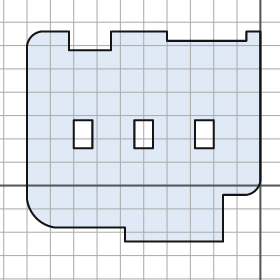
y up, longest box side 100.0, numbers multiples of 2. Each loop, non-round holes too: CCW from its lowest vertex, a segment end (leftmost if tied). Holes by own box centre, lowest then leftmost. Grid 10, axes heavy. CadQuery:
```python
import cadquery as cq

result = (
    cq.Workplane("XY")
    .moveTo(-58.0, -24.0)
    .lineTo(-16.0, -24.0)
    .lineTo(-16.0, -4.0)
    .lineTo(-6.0, -4.0)
    .threePointArc((-2.0, -2.0), (0.0, 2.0))
    .lineTo(0.0, 66.0)
    .lineTo(-6.0, 66.0)
    .lineTo(-6.0, 62.0)
    .lineTo(-40.0, 62.0)
    .lineTo(-40.0, 66.0)
    .lineTo(-64.0, 66.0)
    .lineTo(-64.0, 58.0)
    .lineTo(-82.0, 58.0)
    .lineTo(-82.0, 66.0)
    .lineTo(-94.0, 66.0)
    .threePointArc((-98.0, 64.0), (-100.0, 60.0))
    .lineTo(-100.0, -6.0)
    .threePointArc((-96.0, -14.0), (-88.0, -18.0))
    .lineTo(-58.0, -18.0)
    .close()
    .moveTo(-80.0, 16.0)
    .lineTo(-72.0, 16.0)
    .lineTo(-72.0, 28.0)
    .lineTo(-80.0, 28.0)
    .close()
    .moveTo(-54.0, 16.0)
    .lineTo(-46.0, 16.0)
    .lineTo(-46.0, 28.0)
    .lineTo(-54.0, 28.0)
    .close()
    .moveTo(-28.0, 16.0)
    .lineTo(-20.0, 16.0)
    .lineTo(-20.0, 28.0)
    .lineTo(-28.0, 28.0)
    .close()
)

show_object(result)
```